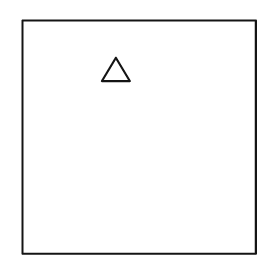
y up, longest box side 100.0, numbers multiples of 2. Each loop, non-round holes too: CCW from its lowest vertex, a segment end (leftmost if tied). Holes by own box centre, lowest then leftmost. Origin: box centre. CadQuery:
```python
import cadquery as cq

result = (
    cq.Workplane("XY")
    .moveTo(-50.0, -50.0)
    .lineTo(50.0, -50.0)
    .lineTo(50.0, 50.0)
    .lineTo(-50.0, 50.0)
    .close()
    .moveTo(-16.0, 24.0)
    .lineTo(-4.0, 24.0)
    .lineTo(-10.0, 34.0)
    .close()
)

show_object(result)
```